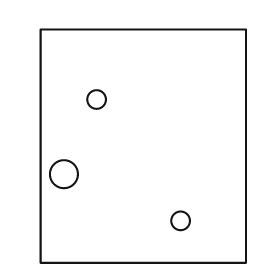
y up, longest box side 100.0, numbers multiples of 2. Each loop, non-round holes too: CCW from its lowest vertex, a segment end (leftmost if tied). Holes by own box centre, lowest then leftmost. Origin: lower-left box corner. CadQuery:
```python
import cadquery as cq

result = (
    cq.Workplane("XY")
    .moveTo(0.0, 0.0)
    .lineTo(88.0, 0.0)
    .lineTo(88.0, 100.0)
    .lineTo(0.0, 100.0)
    .close()
    .moveTo(60.0, 18.0)
    .circle(4.0)
    .moveTo(10.0, 38.0)
    .circle(6.0)
    .moveTo(24.0, 70.0)
    .circle(4.0)
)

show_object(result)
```